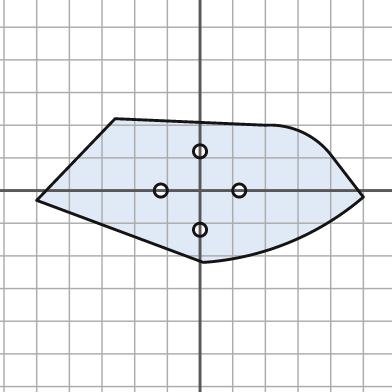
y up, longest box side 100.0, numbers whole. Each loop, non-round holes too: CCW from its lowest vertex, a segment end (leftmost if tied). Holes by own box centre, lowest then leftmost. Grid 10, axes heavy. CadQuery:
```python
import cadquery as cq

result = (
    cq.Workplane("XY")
    .moveTo(1.0, -22.0)
    .threePointArc((27.0, -16.0), (50.0, -2.0))
    .lineTo(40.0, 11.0)
    .threePointArc((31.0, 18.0), (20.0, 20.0))
    .lineTo(-26.0, 22.0)
    .lineTo(-50.0, -3.0)
    .close()
    .moveTo(0.0, -12.0)
    .circle(2.0)
    .moveTo(-12.0, 0.0)
    .circle(2.0)
    .moveTo(12.0, 0.0)
    .circle(2.0)
    .moveTo(0.0, 12.0)
    .circle(2.0)
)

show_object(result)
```